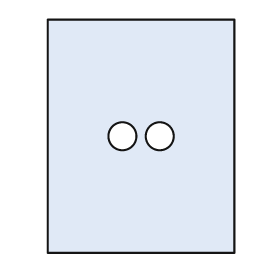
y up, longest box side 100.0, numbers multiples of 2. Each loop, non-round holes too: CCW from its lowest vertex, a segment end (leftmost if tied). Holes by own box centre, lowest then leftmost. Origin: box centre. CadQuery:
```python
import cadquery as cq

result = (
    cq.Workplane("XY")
    .moveTo(-40.0, -50.0)
    .lineTo(40.0, -50.0)
    .lineTo(40.0, 50.0)
    .lineTo(-40.0, 50.0)
    .close()
    .moveTo(-8.0, 0.0)
    .circle(6.0)
    .moveTo(8.0, 0.0)
    .circle(6.0)
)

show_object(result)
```